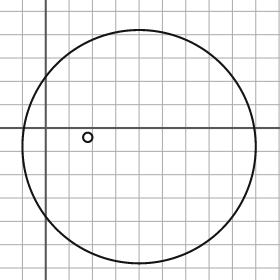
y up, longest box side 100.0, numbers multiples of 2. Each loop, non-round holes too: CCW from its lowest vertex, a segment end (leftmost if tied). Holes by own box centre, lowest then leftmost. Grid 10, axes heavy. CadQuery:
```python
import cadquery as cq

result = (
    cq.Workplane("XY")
    .moveTo(40.0, -8.0)
    .circle(50.0)
    .moveTo(18.0, -4.0)
    .circle(2.0)
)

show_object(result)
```